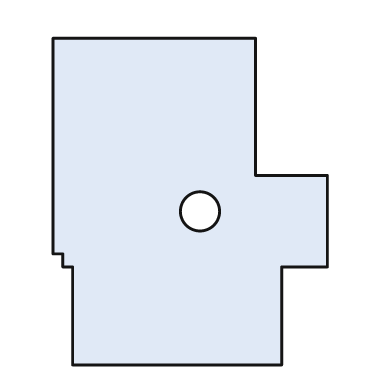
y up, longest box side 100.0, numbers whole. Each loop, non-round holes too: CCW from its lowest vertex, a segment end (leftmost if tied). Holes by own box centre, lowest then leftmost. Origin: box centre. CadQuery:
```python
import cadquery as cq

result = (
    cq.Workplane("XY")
    .moveTo(-36.0, -50.0)
    .lineTo(28.0, -50.0)
    .lineTo(28.0, -20.0)
    .lineTo(42.0, -20.0)
    .lineTo(42.0, 8.0)
    .lineTo(20.0, 8.0)
    .lineTo(20.0, 50.0)
    .lineTo(-42.0, 50.0)
    .lineTo(-42.0, -16.0)
    .lineTo(-39.0, -16.0)
    .lineTo(-39.0, -20.0)
    .lineTo(-36.0, -20.0)
    .close()
    .moveTo(3.0, -3.0)
    .circle(6.0)
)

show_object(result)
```